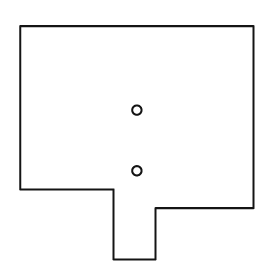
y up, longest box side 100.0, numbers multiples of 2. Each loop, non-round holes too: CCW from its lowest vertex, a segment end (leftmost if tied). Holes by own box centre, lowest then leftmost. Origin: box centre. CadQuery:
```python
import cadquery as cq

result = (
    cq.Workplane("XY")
    .moveTo(-10.0, -50.0)
    .lineTo(8.0, -50.0)
    .lineTo(8.0, -28.0)
    .lineTo(50.0, -28.0)
    .lineTo(50.0, 50.0)
    .lineTo(-50.0, 50.0)
    .lineTo(-50.0, -20.0)
    .lineTo(-10.0, -20.0)
    .close()
    .moveTo(0.0, -12.0)
    .circle(2.0)
    .moveTo(0.0, 14.0)
    .circle(2.0)
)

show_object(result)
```